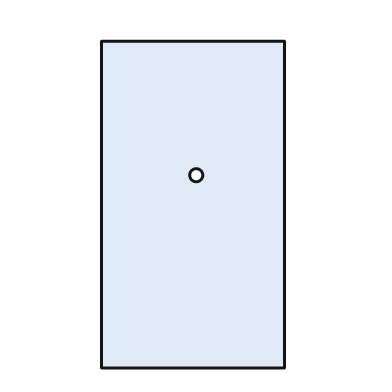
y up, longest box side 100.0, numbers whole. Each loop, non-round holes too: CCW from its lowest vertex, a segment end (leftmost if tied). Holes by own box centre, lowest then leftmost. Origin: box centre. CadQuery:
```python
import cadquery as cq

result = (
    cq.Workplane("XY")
    .moveTo(-28.0, -50.0)
    .lineTo(28.0, -50.0)
    .lineTo(28.0, 50.0)
    .lineTo(-28.0, 50.0)
    .close()
    .moveTo(1.0, 9.0)
    .circle(2.0)
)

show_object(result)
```